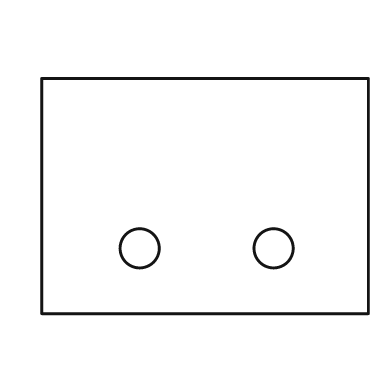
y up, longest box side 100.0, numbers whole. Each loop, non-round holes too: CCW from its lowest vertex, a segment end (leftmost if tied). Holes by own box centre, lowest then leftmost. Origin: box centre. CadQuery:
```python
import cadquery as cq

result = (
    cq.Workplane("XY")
    .moveTo(-50.0, -36.0)
    .lineTo(50.0, -36.0)
    .lineTo(50.0, 36.0)
    .lineTo(-50.0, 36.0)
    .close()
    .moveTo(-20.0, -16.0)
    .circle(6.0)
    .moveTo(21.0, -16.0)
    .circle(6.0)
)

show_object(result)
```